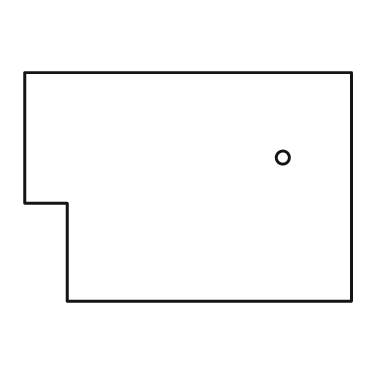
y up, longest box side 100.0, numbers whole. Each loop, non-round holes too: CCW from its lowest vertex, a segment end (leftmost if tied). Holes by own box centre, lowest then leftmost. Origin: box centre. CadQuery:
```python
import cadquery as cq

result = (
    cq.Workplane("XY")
    .moveTo(-37.0, -35.0)
    .lineTo(50.0, -35.0)
    .lineTo(50.0, 35.0)
    .lineTo(-50.0, 35.0)
    .lineTo(-50.0, -5.0)
    .lineTo(-37.0, -5.0)
    .close()
    .moveTo(29.0, 9.0)
    .circle(2.0)
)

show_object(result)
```